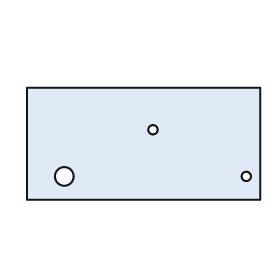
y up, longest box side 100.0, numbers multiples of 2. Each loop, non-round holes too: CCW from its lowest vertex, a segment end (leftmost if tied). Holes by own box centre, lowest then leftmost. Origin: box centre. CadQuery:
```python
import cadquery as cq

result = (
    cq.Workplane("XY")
    .moveTo(-50.0, -24.0)
    .lineTo(50.0, -24.0)
    .lineTo(50.0, 24.0)
    .lineTo(-50.0, 24.0)
    .close()
    .moveTo(-34.0, -14.0)
    .circle(4.0)
    .moveTo(44.0, -14.0)
    .circle(2.0)
    .moveTo(4.0, 6.0)
    .circle(2.0)
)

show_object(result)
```